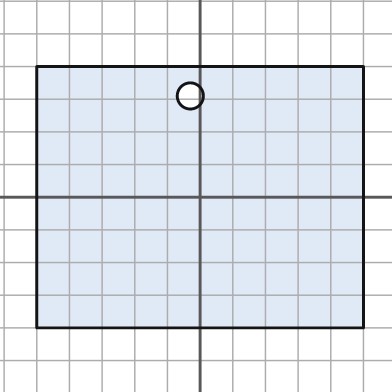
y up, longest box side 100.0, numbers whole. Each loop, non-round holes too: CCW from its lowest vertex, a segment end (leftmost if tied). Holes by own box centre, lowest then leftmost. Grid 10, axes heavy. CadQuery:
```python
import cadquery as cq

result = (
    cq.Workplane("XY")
    .moveTo(-50.0, -40.0)
    .lineTo(50.0, -40.0)
    .lineTo(50.0, 40.0)
    .lineTo(-50.0, 40.0)
    .close()
    .moveTo(-3.0, 31.0)
    .circle(4.0)
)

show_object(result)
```